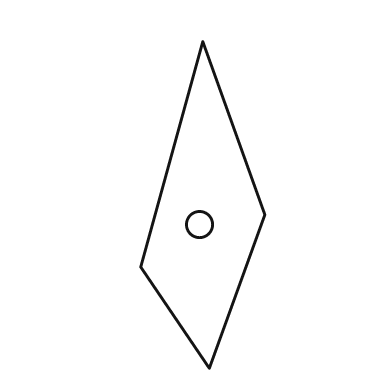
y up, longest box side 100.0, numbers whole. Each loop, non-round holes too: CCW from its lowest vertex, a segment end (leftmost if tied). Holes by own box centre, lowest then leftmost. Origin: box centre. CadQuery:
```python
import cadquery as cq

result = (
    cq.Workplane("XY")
    .moveTo(2.0, -50.0)
    .lineTo(19.0, -3.0)
    .lineTo(0.0, 50.0)
    .lineTo(-19.0, -19.0)
    .close()
    .moveTo(-1.0, -6.0)
    .circle(4.0)
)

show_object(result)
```